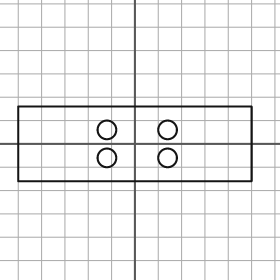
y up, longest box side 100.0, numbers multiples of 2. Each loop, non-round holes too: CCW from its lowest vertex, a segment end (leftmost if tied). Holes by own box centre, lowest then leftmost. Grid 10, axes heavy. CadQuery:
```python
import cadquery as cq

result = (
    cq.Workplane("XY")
    .moveTo(-50.0, -16.0)
    .lineTo(50.0, -16.0)
    .lineTo(50.0, 16.0)
    .lineTo(-50.0, 16.0)
    .close()
    .moveTo(-12.0, -6.0)
    .circle(4.0)
    .moveTo(14.0, -6.0)
    .circle(4.0)
    .moveTo(-12.0, 6.0)
    .circle(4.0)
    .moveTo(14.0, 6.0)
    .circle(4.0)
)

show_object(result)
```